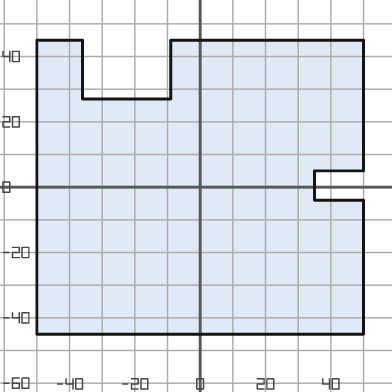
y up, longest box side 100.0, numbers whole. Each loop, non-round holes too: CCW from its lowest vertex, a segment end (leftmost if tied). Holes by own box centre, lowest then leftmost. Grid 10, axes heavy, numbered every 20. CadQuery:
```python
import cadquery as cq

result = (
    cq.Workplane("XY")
    .moveTo(-50.0, -45.0)
    .lineTo(50.0, -45.0)
    .lineTo(50.0, -4.0)
    .lineTo(35.0, -4.0)
    .lineTo(35.0, 5.0)
    .lineTo(50.0, 5.0)
    .lineTo(50.0, 45.0)
    .lineTo(-9.0, 45.0)
    .lineTo(-9.0, 27.0)
    .lineTo(-36.0, 27.0)
    .lineTo(-36.0, 45.0)
    .lineTo(-50.0, 45.0)
    .close()
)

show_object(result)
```